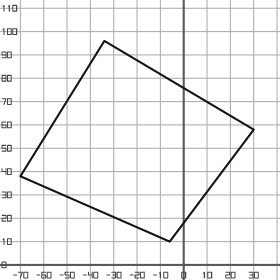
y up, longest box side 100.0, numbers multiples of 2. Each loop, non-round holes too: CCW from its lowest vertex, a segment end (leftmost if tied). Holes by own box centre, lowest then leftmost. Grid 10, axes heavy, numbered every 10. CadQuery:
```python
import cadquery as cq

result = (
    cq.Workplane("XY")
    .moveTo(-6.0, 10.0)
    .lineTo(30.0, 58.0)
    .lineTo(-34.0, 96.0)
    .lineTo(-70.0, 38.0)
    .close()
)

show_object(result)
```